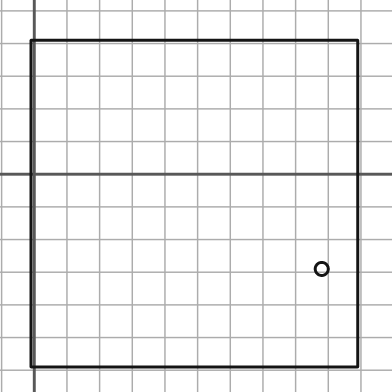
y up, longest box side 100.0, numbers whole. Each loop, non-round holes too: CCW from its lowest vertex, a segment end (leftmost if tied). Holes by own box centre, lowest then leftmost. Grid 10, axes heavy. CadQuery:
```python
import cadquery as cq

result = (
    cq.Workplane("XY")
    .moveTo(-1.0, -59.0)
    .lineTo(99.0, -59.0)
    .lineTo(99.0, 41.0)
    .lineTo(-1.0, 41.0)
    .close()
    .moveTo(88.0, -29.0)
    .circle(2.0)
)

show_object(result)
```